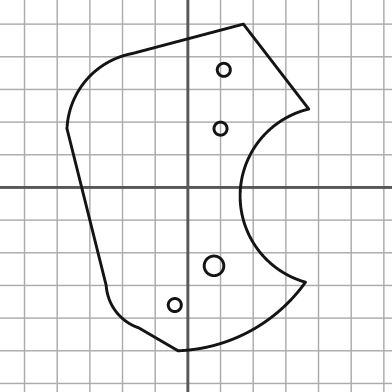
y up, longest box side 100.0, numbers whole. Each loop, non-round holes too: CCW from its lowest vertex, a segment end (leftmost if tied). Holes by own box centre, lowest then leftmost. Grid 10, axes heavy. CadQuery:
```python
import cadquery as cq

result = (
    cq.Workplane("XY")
    .moveTo(-3.0, -50.0)
    .threePointArc((19.0, -44.0), (36.0, -29.0))
    .threePointArc((16.0, -2.0), (37.0, 24.0))
    .lineTo(17.0, 50.0)
    .lineTo(-17.0, 41.0)
    .threePointArc((-31.0, 33.0), (-37.0, 18.0))
    .lineTo(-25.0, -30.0)
    .threePointArc((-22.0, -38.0), (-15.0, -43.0))
    .close()
    .moveTo(-4.0, -36.0)
    .circle(2.0)
    .moveTo(8.0, -24.0)
    .circle(3.0)
    .moveTo(10.0, 18.0)
    .circle(2.0)
    .moveTo(11.0, 36.0)
    .circle(2.0)
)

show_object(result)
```